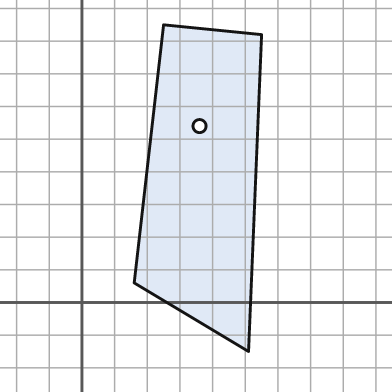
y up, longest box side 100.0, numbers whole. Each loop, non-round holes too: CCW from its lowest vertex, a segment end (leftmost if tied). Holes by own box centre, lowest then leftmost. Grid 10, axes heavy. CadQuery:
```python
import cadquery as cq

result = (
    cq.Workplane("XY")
    .moveTo(51.0, -15.0)
    .lineTo(55.0, 82.0)
    .lineTo(25.0, 85.0)
    .lineTo(16.0, 6.0)
    .close()
    .moveTo(36.0, 54.0)
    .circle(2.0)
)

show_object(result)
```